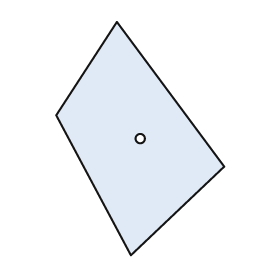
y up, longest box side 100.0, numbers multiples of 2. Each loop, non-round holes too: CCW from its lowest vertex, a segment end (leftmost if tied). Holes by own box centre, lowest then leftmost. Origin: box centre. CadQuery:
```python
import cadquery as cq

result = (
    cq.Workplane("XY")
    .moveTo(-4.0, -50.0)
    .lineTo(36.0, -12.0)
    .lineTo(-10.0, 50.0)
    .lineTo(-36.0, 10.0)
    .close()
    .moveTo(0.0, 0.0)
    .circle(2.0)
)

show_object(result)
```